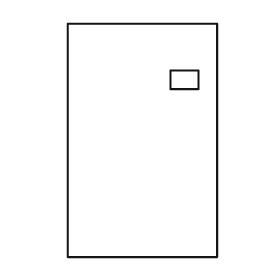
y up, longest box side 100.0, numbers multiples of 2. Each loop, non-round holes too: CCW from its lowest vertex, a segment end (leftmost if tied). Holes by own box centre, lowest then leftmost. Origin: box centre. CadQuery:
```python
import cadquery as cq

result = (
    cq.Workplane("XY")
    .moveTo(-32.0, -50.0)
    .lineTo(32.0, -50.0)
    .lineTo(32.0, 50.0)
    .lineTo(-32.0, 50.0)
    .close()
    .moveTo(12.0, 22.0)
    .lineTo(24.0, 22.0)
    .lineTo(24.0, 30.0)
    .lineTo(12.0, 30.0)
    .close()
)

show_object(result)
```